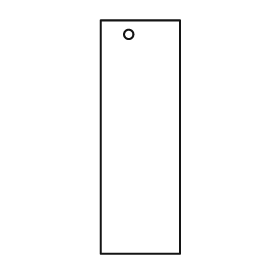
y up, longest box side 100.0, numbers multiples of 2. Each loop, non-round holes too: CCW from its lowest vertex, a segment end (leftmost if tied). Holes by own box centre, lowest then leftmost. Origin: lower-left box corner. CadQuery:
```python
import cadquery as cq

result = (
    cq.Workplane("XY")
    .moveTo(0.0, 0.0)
    .lineTo(34.0, 0.0)
    .lineTo(34.0, 100.0)
    .lineTo(0.0, 100.0)
    .close()
    .moveTo(12.0, 94.0)
    .circle(2.0)
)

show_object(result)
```